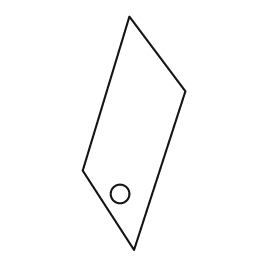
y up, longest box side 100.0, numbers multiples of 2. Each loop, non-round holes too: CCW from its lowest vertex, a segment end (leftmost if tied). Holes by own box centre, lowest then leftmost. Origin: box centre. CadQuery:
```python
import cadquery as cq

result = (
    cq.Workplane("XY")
    .moveTo(0.0, -50.0)
    .lineTo(22.0, 18.0)
    .lineTo(-2.0, 50.0)
    .lineTo(-22.0, -16.0)
    .close()
    .moveTo(-6.0, -26.0)
    .circle(4.0)
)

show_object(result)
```